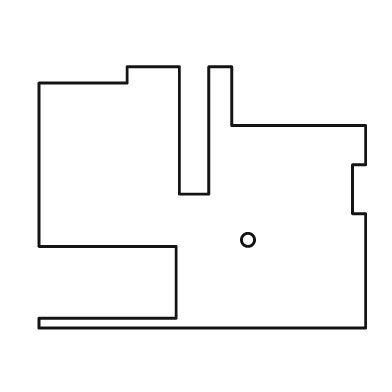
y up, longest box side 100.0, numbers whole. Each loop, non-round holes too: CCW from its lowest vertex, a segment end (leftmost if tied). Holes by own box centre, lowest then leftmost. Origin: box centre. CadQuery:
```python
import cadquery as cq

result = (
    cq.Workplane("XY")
    .moveTo(-50.0, -40.0)
    .lineTo(50.0, -40.0)
    .lineTo(50.0, -5.0)
    .lineTo(46.0, -5.0)
    .lineTo(46.0, 10.0)
    .lineTo(50.0, 10.0)
    .lineTo(50.0, 22.0)
    .lineTo(9.0, 22.0)
    .lineTo(9.0, 40.0)
    .lineTo(2.0, 40.0)
    .lineTo(2.0, 1.0)
    .lineTo(-7.0, 1.0)
    .lineTo(-7.0, 40.0)
    .lineTo(-23.0, 40.0)
    .lineTo(-23.0, 35.0)
    .lineTo(-50.0, 35.0)
    .lineTo(-50.0, -15.0)
    .lineTo(-8.0, -15.0)
    .lineTo(-8.0, -37.0)
    .lineTo(-50.0, -37.0)
    .close()
    .moveTo(14.0, -13.0)
    .circle(2.0)
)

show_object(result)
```